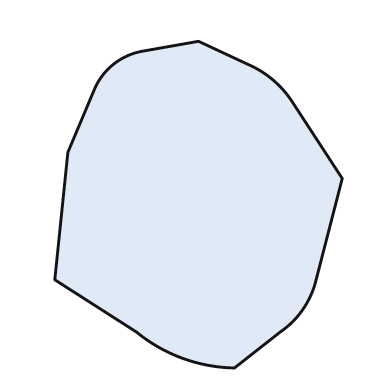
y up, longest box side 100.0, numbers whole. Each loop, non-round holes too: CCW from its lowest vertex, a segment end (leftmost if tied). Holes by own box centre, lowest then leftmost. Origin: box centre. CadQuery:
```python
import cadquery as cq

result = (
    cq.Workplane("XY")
    .moveTo(11.0, -50.0)
    .lineTo(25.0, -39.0)
    .threePointArc((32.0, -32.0), (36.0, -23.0))
    .lineTo(44.0, 8.0)
    .lineTo(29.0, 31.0)
    .threePointArc((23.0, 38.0), (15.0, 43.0))
    .lineTo(0.0, 50.0)
    .lineTo(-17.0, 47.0)
    .threePointArc((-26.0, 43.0), (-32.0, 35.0))
    .lineTo(-40.0, 16.0)
    .lineTo(-44.0, -23.0)
    .lineTo(-19.0, -39.0)
    .threePointArc((-5.0, -47.0), (11.0, -50.0))
    .close()
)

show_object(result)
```